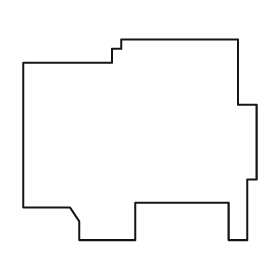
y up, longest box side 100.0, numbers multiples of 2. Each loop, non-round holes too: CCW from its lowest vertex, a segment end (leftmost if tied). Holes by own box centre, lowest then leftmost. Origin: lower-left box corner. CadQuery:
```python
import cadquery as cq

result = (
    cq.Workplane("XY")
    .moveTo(24.0, 0.0)
    .lineTo(48.0, 0.0)
    .lineTo(48.0, 16.0)
    .lineTo(88.0, 16.0)
    .lineTo(88.0, 0.0)
    .lineTo(96.0, 0.0)
    .lineTo(96.0, 26.0)
    .lineTo(100.0, 26.0)
    .lineTo(100.0, 58.0)
    .lineTo(92.0, 58.0)
    .lineTo(92.0, 86.0)
    .lineTo(42.0, 86.0)
    .lineTo(42.0, 82.0)
    .lineTo(38.0, 82.0)
    .lineTo(38.0, 76.0)
    .lineTo(0.0, 76.0)
    .lineTo(0.0, 14.0)
    .lineTo(20.0, 14.0)
    .lineTo(24.0, 8.0)
    .close()
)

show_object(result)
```